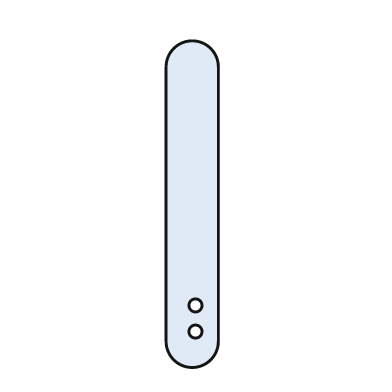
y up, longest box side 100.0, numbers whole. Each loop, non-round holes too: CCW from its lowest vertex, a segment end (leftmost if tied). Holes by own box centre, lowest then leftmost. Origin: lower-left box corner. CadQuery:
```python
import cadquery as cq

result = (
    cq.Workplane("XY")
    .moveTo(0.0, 8.0)
    .threePointArc((8.0, 0.0), (16.0, 8.0))
    .lineTo(16.0, 92.0)
    .threePointArc((8.0, 100.0), (0.0, 92.0))
    .close()
    .moveTo(9.0, 11.0)
    .circle(2.0)
    .moveTo(9.0, 19.0)
    .circle(2.0)
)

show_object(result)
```